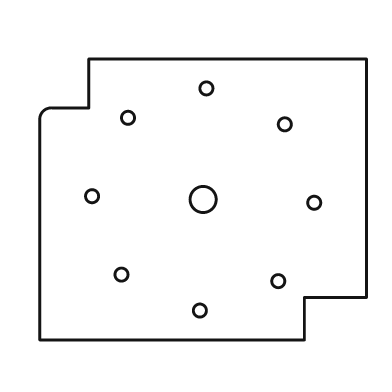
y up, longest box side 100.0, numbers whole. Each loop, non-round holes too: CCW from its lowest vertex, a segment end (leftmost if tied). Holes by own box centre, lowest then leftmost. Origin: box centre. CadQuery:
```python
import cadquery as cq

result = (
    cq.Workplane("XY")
    .moveTo(-50.0, -43.0)
    .lineTo(31.0, -43.0)
    .lineTo(31.0, -30.0)
    .lineTo(50.0, -30.0)
    .lineTo(50.0, 43.0)
    .lineTo(-35.0, 43.0)
    .lineTo(-35.0, 28.0)
    .lineTo(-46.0, 28.0)
    .threePointArc((-49.0, 27.0), (-50.0, 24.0))
    .close()
    .moveTo(-1.0, -34.0)
    .circle(2.0)
    .moveTo(23.0, -25.0)
    .circle(2.0)
    .moveTo(-25.0, -23.0)
    .circle(2.0)
    .moveTo(34.0, -1.0)
    .circle(2.0)
    .moveTo(0.0, 0.0)
    .circle(4.0)
    .moveTo(-34.0, 1.0)
    .circle(2.0)
    .moveTo(25.0, 23.0)
    .circle(2.0)
    .moveTo(-23.0, 25.0)
    .circle(2.0)
    .moveTo(1.0, 34.0)
    .circle(2.0)
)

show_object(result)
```